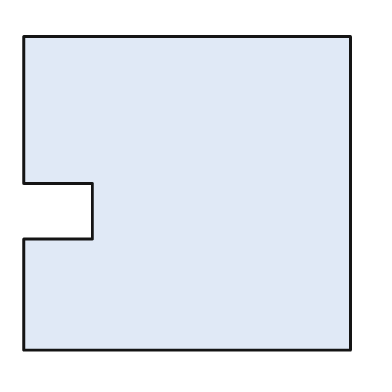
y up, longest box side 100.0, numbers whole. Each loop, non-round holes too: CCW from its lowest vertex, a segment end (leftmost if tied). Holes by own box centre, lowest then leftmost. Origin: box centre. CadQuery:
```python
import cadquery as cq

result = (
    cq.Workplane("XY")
    .moveTo(-50.0, -48.0)
    .lineTo(50.0, -48.0)
    .lineTo(50.0, 48.0)
    .lineTo(-50.0, 48.0)
    .lineTo(-50.0, 3.0)
    .lineTo(-29.0, 3.0)
    .lineTo(-29.0, -14.0)
    .lineTo(-50.0, -14.0)
    .close()
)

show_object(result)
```